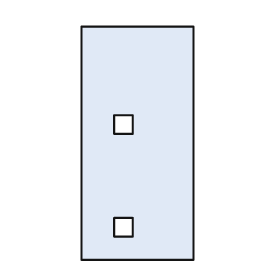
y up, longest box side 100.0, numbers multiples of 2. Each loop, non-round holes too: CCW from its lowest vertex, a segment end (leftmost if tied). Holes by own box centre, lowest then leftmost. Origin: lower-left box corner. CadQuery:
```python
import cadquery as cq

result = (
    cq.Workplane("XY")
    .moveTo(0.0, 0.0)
    .lineTo(48.0, 0.0)
    .lineTo(48.0, 100.0)
    .lineTo(0.0, 100.0)
    .close()
    .moveTo(14.0, 10.0)
    .lineTo(22.0, 10.0)
    .lineTo(22.0, 18.0)
    .lineTo(14.0, 18.0)
    .close()
    .moveTo(14.0, 54.0)
    .lineTo(22.0, 54.0)
    .lineTo(22.0, 62.0)
    .lineTo(14.0, 62.0)
    .close()
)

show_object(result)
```